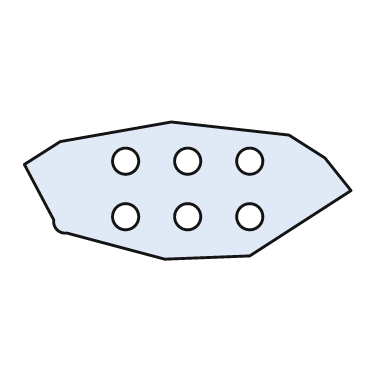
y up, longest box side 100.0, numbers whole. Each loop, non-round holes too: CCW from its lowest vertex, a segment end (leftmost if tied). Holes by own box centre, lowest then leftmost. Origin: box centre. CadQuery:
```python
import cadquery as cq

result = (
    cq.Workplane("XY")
    .moveTo(-7.0, -21.0)
    .lineTo(19.0, -20.0)
    .lineTo(50.0, 0.0)
    .lineTo(42.0, 10.0)
    .lineTo(31.0, 17.0)
    .lineTo(-5.0, 21.0)
    .lineTo(-39.0, 15.0)
    .lineTo(-50.0, 8.0)
    .lineTo(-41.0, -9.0)
    .threePointArc((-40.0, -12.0), (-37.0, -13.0))
    .close()
    .moveTo(-19.0, -8.0)
    .circle(4.0)
    .moveTo(0.0, -8.0)
    .circle(4.0)
    .moveTo(19.0, -8.0)
    .circle(4.0)
    .moveTo(-19.0, 9.0)
    .circle(4.0)
    .moveTo(0.0, 9.0)
    .circle(4.0)
    .moveTo(19.0, 9.0)
    .circle(4.0)
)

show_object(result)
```